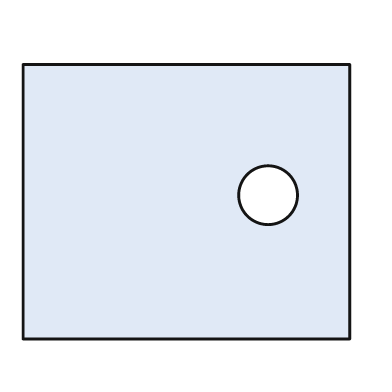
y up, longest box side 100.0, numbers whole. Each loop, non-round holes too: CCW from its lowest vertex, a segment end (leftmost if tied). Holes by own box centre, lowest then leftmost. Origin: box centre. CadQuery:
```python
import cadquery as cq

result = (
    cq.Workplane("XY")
    .moveTo(-50.0, -42.0)
    .lineTo(50.0, -42.0)
    .lineTo(50.0, 42.0)
    .lineTo(-50.0, 42.0)
    .close()
    .moveTo(25.0, 2.0)
    .circle(9.0)
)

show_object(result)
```